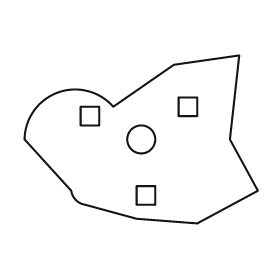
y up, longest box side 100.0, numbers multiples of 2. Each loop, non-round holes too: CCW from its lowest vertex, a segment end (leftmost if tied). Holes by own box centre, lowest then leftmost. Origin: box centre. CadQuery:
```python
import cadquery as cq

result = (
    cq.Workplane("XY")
    .moveTo(24.0, -36.0)
    .lineTo(50.0, -22.0)
    .lineTo(38.0, 0.0)
    .lineTo(42.0, 36.0)
    .lineTo(14.0, 32.0)
    .lineTo(-12.0, 14.0)
    .threePointArc((-36.0, 20.0), (-50.0, 0.0))
    .lineTo(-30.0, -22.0)
    .threePointArc((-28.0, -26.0), (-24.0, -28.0))
    .lineTo(-2.0, -34.0)
    .close()
    .moveTo(-2.0, -28.0)
    .lineTo(6.0, -28.0)
    .lineTo(6.0, -20.0)
    .lineTo(-2.0, -20.0)
    .close()
    .moveTo(0.0, 0.0)
    .circle(6.0)
    .moveTo(-26.0, 6.0)
    .lineTo(-18.0, 6.0)
    .lineTo(-18.0, 14.0)
    .lineTo(-26.0, 14.0)
    .close()
    .moveTo(16.0, 10.0)
    .lineTo(24.0, 10.0)
    .lineTo(24.0, 18.0)
    .lineTo(16.0, 18.0)
    .close()
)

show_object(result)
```